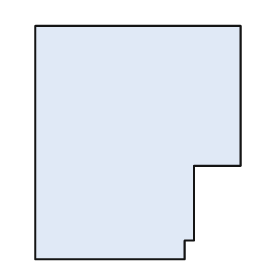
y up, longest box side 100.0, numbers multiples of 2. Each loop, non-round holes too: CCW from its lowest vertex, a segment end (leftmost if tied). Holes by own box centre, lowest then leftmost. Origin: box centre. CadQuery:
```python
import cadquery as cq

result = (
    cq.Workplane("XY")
    .moveTo(-44.0, -50.0)
    .lineTo(20.0, -50.0)
    .lineTo(20.0, -42.0)
    .lineTo(24.0, -42.0)
    .lineTo(24.0, -10.0)
    .lineTo(44.0, -10.0)
    .lineTo(44.0, 50.0)
    .lineTo(-44.0, 50.0)
    .close()
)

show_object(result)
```